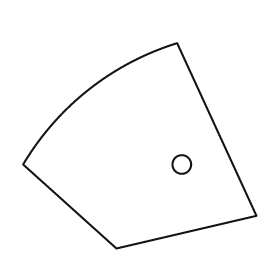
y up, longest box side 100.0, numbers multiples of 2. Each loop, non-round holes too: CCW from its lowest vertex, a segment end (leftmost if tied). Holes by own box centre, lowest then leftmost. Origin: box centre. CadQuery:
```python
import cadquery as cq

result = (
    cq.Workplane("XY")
    .moveTo(-10.0, -44.0)
    .lineTo(50.0, -30.0)
    .lineTo(16.0, 44.0)
    .threePointArc((-22.0, 24.0), (-50.0, -8.0))
    .close()
    .moveTo(18.0, -8.0)
    .circle(4.0)
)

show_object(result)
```